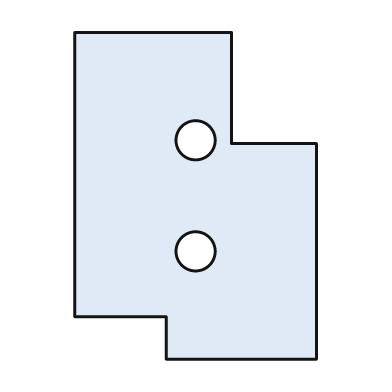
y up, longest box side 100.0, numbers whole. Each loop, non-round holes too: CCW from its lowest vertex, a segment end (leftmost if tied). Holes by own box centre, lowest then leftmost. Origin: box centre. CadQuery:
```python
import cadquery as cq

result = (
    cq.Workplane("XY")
    .moveTo(-9.0, -50.0)
    .lineTo(37.0, -50.0)
    .lineTo(37.0, 16.0)
    .lineTo(11.0, 16.0)
    .lineTo(11.0, 50.0)
    .lineTo(-37.0, 50.0)
    .lineTo(-37.0, -37.0)
    .lineTo(-9.0, -37.0)
    .close()
    .moveTo(0.0, -17.0)
    .circle(6.0)
    .moveTo(0.0, 17.0)
    .circle(6.0)
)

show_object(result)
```